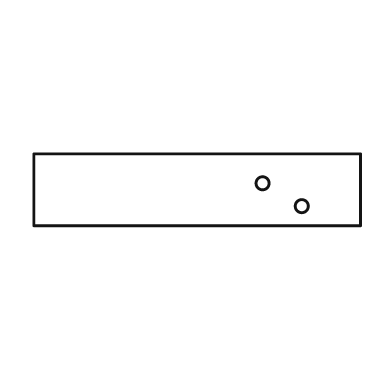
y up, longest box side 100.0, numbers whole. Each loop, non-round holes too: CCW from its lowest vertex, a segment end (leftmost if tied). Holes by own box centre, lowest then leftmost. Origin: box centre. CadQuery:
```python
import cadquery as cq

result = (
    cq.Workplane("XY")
    .moveTo(-50.0, -11.0)
    .lineTo(50.0, -11.0)
    .lineTo(50.0, 11.0)
    .lineTo(-50.0, 11.0)
    .close()
    .moveTo(32.0, -5.0)
    .circle(2.0)
    .moveTo(20.0, 2.0)
    .circle(2.0)
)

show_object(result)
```